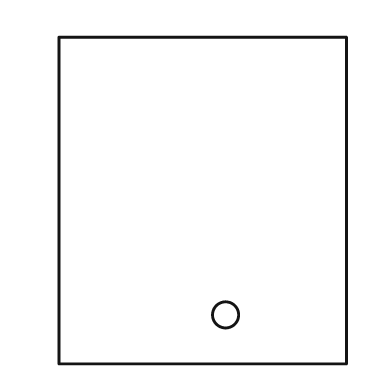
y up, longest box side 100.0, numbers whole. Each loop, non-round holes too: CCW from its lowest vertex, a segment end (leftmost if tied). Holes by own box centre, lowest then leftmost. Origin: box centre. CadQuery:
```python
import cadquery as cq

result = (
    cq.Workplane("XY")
    .moveTo(-44.0, -50.0)
    .lineTo(44.0, -50.0)
    .lineTo(44.0, 50.0)
    .lineTo(-44.0, 50.0)
    .close()
    .moveTo(7.0, -35.0)
    .circle(4.0)
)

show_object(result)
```